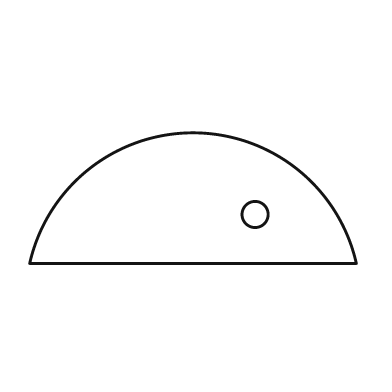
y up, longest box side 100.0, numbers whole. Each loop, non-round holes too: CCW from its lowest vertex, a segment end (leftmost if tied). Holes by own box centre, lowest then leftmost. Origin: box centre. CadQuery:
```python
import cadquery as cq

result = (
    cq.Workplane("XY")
    .moveTo(-50.0, -20.0)
    .lineTo(50.0, -20.0)
    .threePointArc((0.0, 20.0), (-50.0, -20.0))
    .close()
    .moveTo(19.0, -5.0)
    .circle(4.0)
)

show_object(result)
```